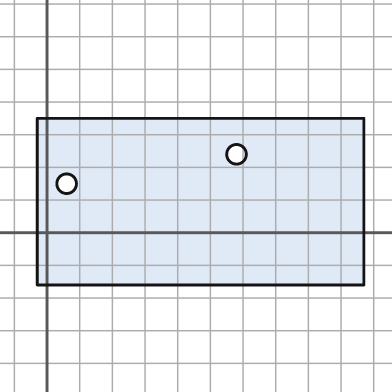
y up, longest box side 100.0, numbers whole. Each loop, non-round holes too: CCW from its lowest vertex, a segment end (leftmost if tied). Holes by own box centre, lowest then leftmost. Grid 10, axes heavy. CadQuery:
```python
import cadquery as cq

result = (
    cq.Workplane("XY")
    .moveTo(-3.0, -16.0)
    .lineTo(97.0, -16.0)
    .lineTo(97.0, 35.0)
    .lineTo(-3.0, 35.0)
    .close()
    .moveTo(6.0, 15.0)
    .circle(3.0)
    .moveTo(58.0, 24.0)
    .circle(3.0)
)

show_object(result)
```